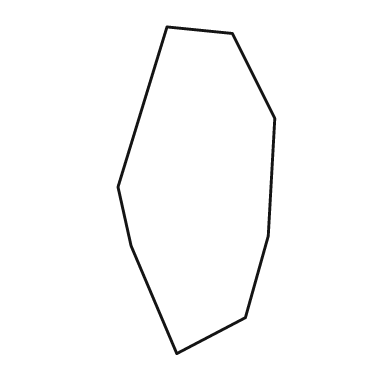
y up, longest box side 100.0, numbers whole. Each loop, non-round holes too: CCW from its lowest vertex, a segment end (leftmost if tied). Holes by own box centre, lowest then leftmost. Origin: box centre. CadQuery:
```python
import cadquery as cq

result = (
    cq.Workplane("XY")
    .moveTo(-6.0, -50.0)
    .lineTo(15.0, -39.0)
    .lineTo(22.0, -14.0)
    .lineTo(24.0, 22.0)
    .lineTo(11.0, 48.0)
    .lineTo(-9.0, 50.0)
    .lineTo(-24.0, 1.0)
    .lineTo(-20.0, -17.0)
    .close()
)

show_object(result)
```